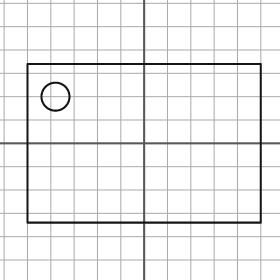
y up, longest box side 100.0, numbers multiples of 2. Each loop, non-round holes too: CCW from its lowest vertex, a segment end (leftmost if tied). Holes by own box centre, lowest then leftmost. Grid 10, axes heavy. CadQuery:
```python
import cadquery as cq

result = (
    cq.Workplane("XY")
    .moveTo(-50.0, -34.0)
    .lineTo(50.0, -34.0)
    .lineTo(50.0, 34.0)
    .lineTo(-50.0, 34.0)
    .close()
    .moveTo(-38.0, 20.0)
    .circle(6.0)
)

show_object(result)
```